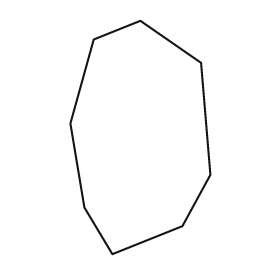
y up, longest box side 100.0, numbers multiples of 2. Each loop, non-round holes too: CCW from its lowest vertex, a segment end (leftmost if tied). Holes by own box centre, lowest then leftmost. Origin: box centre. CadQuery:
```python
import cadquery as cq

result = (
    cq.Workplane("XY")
    .moveTo(-12.0, -50.0)
    .lineTo(18.0, -38.0)
    .lineTo(30.0, -16.0)
    .lineTo(26.0, 32.0)
    .lineTo(0.0, 50.0)
    .lineTo(-20.0, 42.0)
    .lineTo(-30.0, 6.0)
    .lineTo(-24.0, -30.0)
    .close()
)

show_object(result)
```